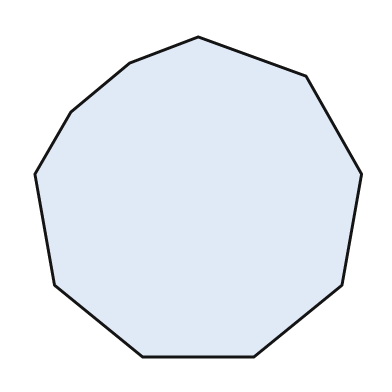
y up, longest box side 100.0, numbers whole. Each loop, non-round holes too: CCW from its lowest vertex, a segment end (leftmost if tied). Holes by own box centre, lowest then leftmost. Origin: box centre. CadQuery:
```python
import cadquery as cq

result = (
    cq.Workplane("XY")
    .moveTo(-17.0, -49.0)
    .lineTo(17.0, -49.0)
    .lineTo(44.0, -27.0)
    .lineTo(50.0, 7.0)
    .lineTo(33.0, 37.0)
    .lineTo(0.0, 49.0)
    .lineTo(-21.0, 41.0)
    .lineTo(-39.0, 26.0)
    .lineTo(-50.0, 7.0)
    .lineTo(-44.0, -27.0)
    .close()
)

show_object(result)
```